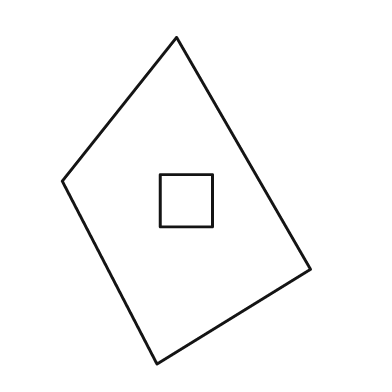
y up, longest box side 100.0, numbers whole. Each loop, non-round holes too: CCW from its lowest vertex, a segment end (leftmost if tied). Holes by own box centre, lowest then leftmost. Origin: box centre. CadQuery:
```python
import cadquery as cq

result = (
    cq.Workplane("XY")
    .moveTo(-9.0, -50.0)
    .lineTo(38.0, -21.0)
    .lineTo(-3.0, 50.0)
    .lineTo(-38.0, 6.0)
    .close()
    .moveTo(-8.0, -8.0)
    .lineTo(8.0, -8.0)
    .lineTo(8.0, 8.0)
    .lineTo(-8.0, 8.0)
    .close()
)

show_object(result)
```